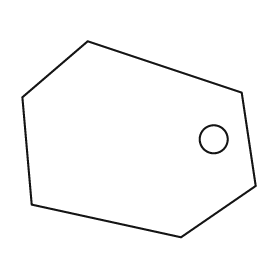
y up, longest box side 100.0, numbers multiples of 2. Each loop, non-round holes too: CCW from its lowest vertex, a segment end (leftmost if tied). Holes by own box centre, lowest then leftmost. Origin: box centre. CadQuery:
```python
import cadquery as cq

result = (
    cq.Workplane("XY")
    .moveTo(18.0, -42.0)
    .lineTo(50.0, -20.0)
    .lineTo(44.0, 20.0)
    .lineTo(-22.0, 42.0)
    .lineTo(-50.0, 18.0)
    .lineTo(-46.0, -28.0)
    .close()
    .moveTo(32.0, 0.0)
    .circle(6.0)
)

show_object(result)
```